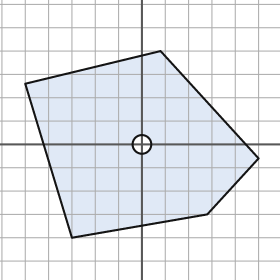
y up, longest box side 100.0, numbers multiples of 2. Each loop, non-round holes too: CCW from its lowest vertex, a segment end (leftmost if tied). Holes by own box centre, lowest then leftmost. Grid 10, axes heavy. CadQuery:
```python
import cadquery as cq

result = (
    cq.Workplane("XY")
    .moveTo(-30.0, -40.0)
    .lineTo(28.0, -30.0)
    .lineTo(50.0, -6.0)
    .lineTo(8.0, 40.0)
    .lineTo(-50.0, 26.0)
    .close()
    .moveTo(0.0, 0.0)
    .circle(4.0)
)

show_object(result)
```